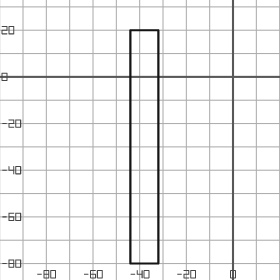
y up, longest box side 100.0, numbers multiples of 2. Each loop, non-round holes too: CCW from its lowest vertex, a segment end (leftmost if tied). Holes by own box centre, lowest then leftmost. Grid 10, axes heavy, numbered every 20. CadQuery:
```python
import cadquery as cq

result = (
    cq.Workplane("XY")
    .moveTo(-44.0, -80.0)
    .lineTo(-32.0, -80.0)
    .lineTo(-32.0, 20.0)
    .lineTo(-44.0, 20.0)
    .close()
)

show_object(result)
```